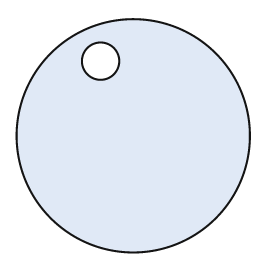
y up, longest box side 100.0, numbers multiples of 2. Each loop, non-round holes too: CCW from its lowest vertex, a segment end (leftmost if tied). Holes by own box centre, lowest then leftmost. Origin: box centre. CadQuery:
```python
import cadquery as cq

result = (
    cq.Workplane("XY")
    .moveTo(0.0, 0.0)
    .circle(50.0)
    .moveTo(-14.0, 32.0)
    .circle(8.0)
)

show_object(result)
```